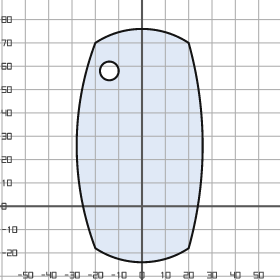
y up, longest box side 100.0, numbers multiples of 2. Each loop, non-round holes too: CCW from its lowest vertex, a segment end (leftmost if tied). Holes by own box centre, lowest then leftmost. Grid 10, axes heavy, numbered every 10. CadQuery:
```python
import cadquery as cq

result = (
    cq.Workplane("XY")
    .moveTo(-20.0, -18.0)
    .threePointArc((0.0, -24.0), (20.0, -18.0))
    .threePointArc((26.0, 26.0), (20.0, 70.0))
    .threePointArc((0.0, 76.0), (-20.0, 70.0))
    .threePointArc((-28.0, 26.0), (-20.0, -18.0))
    .close()
    .moveTo(-14.0, 58.0)
    .circle(4.0)
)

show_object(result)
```